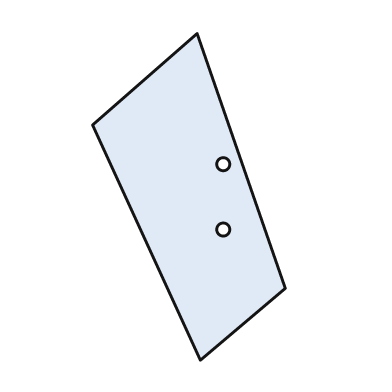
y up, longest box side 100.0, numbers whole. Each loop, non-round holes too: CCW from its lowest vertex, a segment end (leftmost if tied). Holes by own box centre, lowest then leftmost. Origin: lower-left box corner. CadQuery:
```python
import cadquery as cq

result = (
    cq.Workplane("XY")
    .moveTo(33.0, 0.0)
    .lineTo(59.0, 22.0)
    .lineTo(32.0, 100.0)
    .lineTo(0.0, 72.0)
    .close()
    .moveTo(40.0, 40.0)
    .circle(2.0)
    .moveTo(40.0, 60.0)
    .circle(2.0)
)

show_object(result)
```